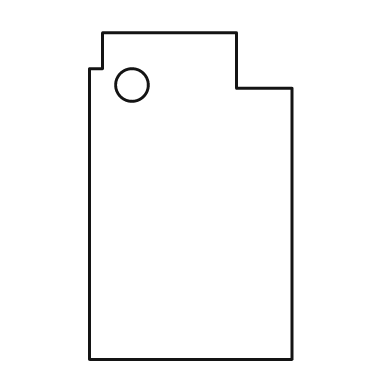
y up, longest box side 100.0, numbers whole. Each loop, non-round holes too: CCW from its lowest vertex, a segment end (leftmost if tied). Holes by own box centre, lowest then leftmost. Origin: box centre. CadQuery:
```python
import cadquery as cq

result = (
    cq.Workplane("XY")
    .moveTo(-31.0, -50.0)
    .lineTo(31.0, -50.0)
    .lineTo(31.0, 33.0)
    .lineTo(14.0, 33.0)
    .lineTo(14.0, 50.0)
    .lineTo(-27.0, 50.0)
    .lineTo(-27.0, 39.0)
    .lineTo(-31.0, 39.0)
    .close()
    .moveTo(-18.0, 34.0)
    .circle(5.0)
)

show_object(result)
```